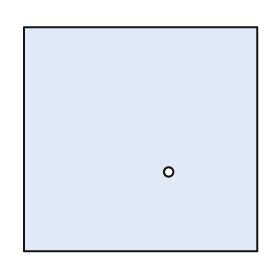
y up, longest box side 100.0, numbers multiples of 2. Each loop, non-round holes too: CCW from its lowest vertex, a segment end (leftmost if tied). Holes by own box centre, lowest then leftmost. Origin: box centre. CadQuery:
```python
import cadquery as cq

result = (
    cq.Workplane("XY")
    .moveTo(-50.0, -48.0)
    .lineTo(50.0, -48.0)
    .lineTo(50.0, 48.0)
    .lineTo(-50.0, 48.0)
    .close()
    .moveTo(12.0, -14.0)
    .circle(2.0)
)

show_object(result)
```